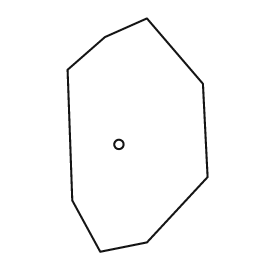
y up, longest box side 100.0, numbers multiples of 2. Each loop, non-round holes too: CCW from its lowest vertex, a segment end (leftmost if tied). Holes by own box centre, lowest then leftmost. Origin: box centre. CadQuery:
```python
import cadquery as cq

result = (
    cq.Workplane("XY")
    .moveTo(-16.0, -50.0)
    .lineTo(4.0, -46.0)
    .lineTo(30.0, -18.0)
    .lineTo(28.0, 22.0)
    .lineTo(4.0, 50.0)
    .lineTo(-14.0, 42.0)
    .lineTo(-30.0, 28.0)
    .lineTo(-28.0, -28.0)
    .close()
    .moveTo(-8.0, -4.0)
    .circle(2.0)
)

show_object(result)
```